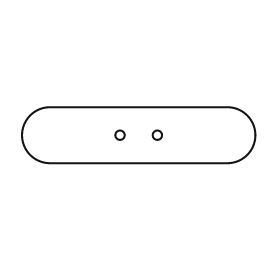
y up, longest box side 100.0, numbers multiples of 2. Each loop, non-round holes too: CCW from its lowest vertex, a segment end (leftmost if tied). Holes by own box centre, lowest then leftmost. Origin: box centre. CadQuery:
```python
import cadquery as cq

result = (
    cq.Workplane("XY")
    .moveTo(-38.0, -12.0)
    .lineTo(38.0, -12.0)
    .threePointArc((50.0, 0.0), (38.0, 12.0))
    .lineTo(-38.0, 12.0)
    .threePointArc((-50.0, 0.0), (-38.0, -12.0))
    .close()
    .moveTo(-8.0, 0.0)
    .circle(2.0)
    .moveTo(8.0, 0.0)
    .circle(2.0)
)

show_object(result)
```